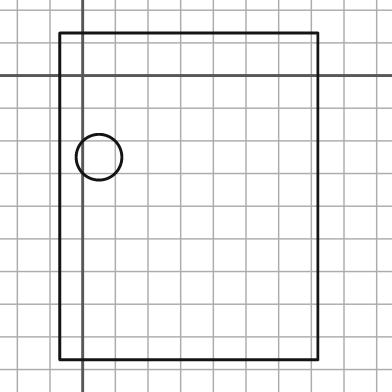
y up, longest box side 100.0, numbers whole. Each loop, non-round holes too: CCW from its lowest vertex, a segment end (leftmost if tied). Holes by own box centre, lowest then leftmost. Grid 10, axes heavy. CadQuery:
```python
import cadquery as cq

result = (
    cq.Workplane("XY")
    .moveTo(-7.0, -87.0)
    .lineTo(72.0, -87.0)
    .lineTo(72.0, 13.0)
    .lineTo(-7.0, 13.0)
    .close()
    .moveTo(5.0, -25.0)
    .circle(7.0)
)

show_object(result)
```